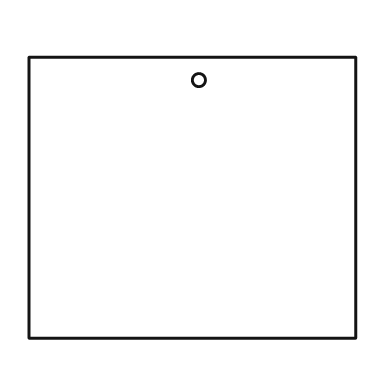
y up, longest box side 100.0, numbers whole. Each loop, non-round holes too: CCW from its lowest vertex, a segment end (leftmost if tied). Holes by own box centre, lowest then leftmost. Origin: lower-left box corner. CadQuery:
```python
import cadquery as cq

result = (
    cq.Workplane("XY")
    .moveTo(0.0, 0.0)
    .lineTo(100.0, 0.0)
    .lineTo(100.0, 86.0)
    .lineTo(0.0, 86.0)
    .close()
    .moveTo(52.0, 79.0)
    .circle(2.0)
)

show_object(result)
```